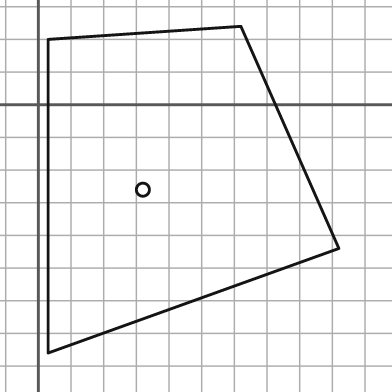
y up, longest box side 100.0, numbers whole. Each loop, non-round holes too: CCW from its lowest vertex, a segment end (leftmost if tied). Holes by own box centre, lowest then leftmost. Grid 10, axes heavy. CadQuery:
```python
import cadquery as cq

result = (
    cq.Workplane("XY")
    .moveTo(3.0, -76.0)
    .lineTo(92.0, -44.0)
    .lineTo(62.0, 24.0)
    .lineTo(3.0, 20.0)
    .close()
    .moveTo(32.0, -26.0)
    .circle(2.0)
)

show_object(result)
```